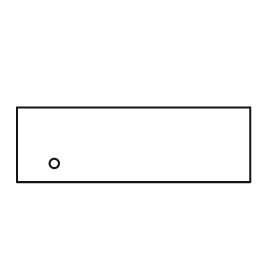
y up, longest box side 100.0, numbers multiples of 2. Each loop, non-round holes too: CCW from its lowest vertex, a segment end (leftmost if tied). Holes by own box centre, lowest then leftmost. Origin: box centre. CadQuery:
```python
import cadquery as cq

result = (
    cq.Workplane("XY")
    .moveTo(-50.0, -16.0)
    .lineTo(50.0, -16.0)
    .lineTo(50.0, 16.0)
    .lineTo(-50.0, 16.0)
    .close()
    .moveTo(-34.0, -8.0)
    .circle(2.0)
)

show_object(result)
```